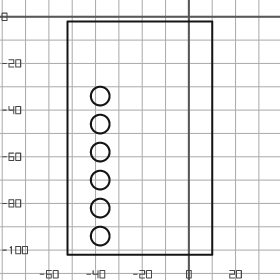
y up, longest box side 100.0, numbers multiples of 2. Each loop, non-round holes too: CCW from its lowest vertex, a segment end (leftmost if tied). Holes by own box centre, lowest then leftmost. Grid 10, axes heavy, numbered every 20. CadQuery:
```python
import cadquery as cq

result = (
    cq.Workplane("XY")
    .moveTo(-52.0, -102.0)
    .lineTo(10.0, -102.0)
    .lineTo(10.0, -2.0)
    .lineTo(-52.0, -2.0)
    .close()
    .moveTo(-38.0, -94.0)
    .circle(4.0)
    .moveTo(-38.0, -82.0)
    .circle(4.0)
    .moveTo(-38.0, -70.0)
    .circle(4.0)
    .moveTo(-38.0, -58.0)
    .circle(4.0)
    .moveTo(-38.0, -46.0)
    .circle(4.0)
    .moveTo(-38.0, -34.0)
    .circle(4.0)
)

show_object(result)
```